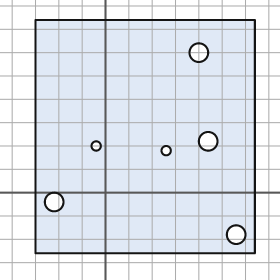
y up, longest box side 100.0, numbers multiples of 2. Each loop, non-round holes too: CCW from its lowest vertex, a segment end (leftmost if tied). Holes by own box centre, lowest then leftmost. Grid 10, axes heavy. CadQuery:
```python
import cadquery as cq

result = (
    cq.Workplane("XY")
    .moveTo(-30.0, -26.0)
    .lineTo(64.0, -26.0)
    .lineTo(64.0, 74.0)
    .lineTo(-30.0, 74.0)
    .close()
    .moveTo(56.0, -18.0)
    .circle(4.0)
    .moveTo(-22.0, -4.0)
    .circle(4.0)
    .moveTo(26.0, 18.0)
    .circle(2.0)
    .moveTo(-4.0, 20.0)
    .circle(2.0)
    .moveTo(44.0, 22.0)
    .circle(4.0)
    .moveTo(40.0, 60.0)
    .circle(4.0)
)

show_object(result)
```